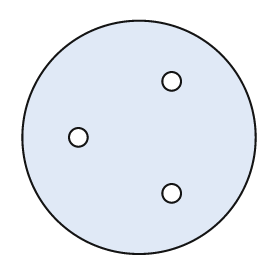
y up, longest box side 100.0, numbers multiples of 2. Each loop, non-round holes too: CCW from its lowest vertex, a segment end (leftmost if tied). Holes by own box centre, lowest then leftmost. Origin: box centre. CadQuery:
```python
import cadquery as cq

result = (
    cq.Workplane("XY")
    .moveTo(0.0, 0.0)
    .circle(50.0)
    .moveTo(14.0, -24.0)
    .circle(4.0)
    .moveTo(-26.0, 0.0)
    .circle(4.0)
    .moveTo(14.0, 24.0)
    .circle(4.0)
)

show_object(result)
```